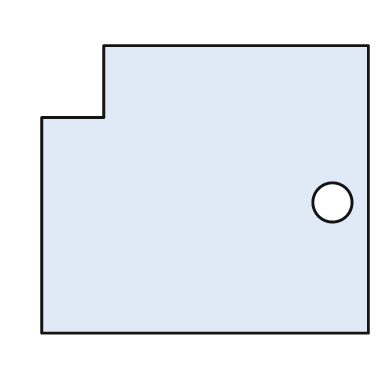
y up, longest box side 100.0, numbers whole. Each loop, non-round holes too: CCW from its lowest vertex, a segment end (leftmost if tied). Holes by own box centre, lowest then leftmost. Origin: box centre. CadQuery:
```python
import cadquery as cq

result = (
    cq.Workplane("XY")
    .moveTo(-50.0, -44.0)
    .lineTo(50.0, -44.0)
    .lineTo(50.0, 44.0)
    .lineTo(-31.0, 44.0)
    .lineTo(-31.0, 22.0)
    .lineTo(-50.0, 22.0)
    .close()
    .moveTo(39.0, -4.0)
    .circle(6.0)
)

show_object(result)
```